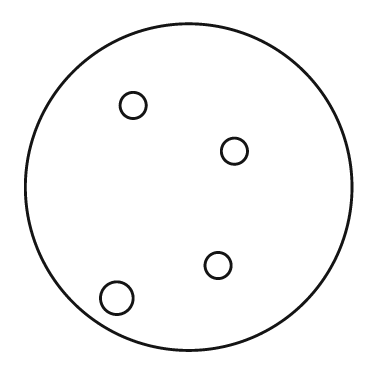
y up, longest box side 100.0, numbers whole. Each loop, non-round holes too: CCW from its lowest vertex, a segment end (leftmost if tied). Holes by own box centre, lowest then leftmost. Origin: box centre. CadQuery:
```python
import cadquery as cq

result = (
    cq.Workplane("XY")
    .moveTo(0.0, 0.0)
    .circle(50.0)
    .moveTo(-22.0, -34.0)
    .circle(5.0)
    .moveTo(9.0, -24.0)
    .circle(4.0)
    .moveTo(14.0, 11.0)
    .circle(4.0)
    .moveTo(-17.0, 25.0)
    .circle(4.0)
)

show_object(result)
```